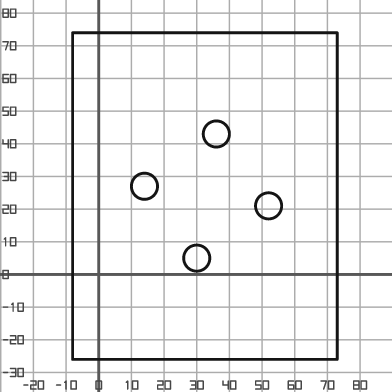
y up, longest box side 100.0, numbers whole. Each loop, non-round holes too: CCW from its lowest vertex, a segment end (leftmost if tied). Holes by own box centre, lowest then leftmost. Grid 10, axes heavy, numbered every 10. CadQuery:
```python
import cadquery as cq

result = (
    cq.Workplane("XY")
    .moveTo(-8.0, -26.0)
    .lineTo(73.0, -26.0)
    .lineTo(73.0, 74.0)
    .lineTo(-8.0, 74.0)
    .close()
    .moveTo(30.0, 5.0)
    .circle(4.0)
    .moveTo(52.0, 21.0)
    .circle(4.0)
    .moveTo(14.0, 27.0)
    .circle(4.0)
    .moveTo(36.0, 43.0)
    .circle(4.0)
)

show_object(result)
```